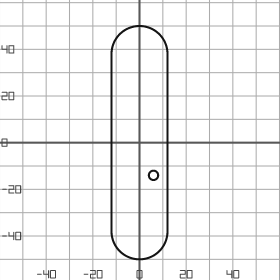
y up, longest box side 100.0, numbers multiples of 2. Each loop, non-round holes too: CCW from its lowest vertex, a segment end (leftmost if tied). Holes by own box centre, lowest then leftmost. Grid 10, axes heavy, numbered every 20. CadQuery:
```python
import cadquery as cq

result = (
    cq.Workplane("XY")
    .moveTo(-12.0, -38.0)
    .threePointArc((0.0, -50.0), (12.0, -38.0))
    .lineTo(12.0, 38.0)
    .threePointArc((0.0, 50.0), (-12.0, 38.0))
    .close()
    .moveTo(6.0, -14.0)
    .circle(2.0)
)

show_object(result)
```